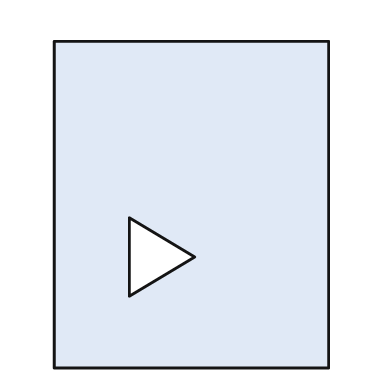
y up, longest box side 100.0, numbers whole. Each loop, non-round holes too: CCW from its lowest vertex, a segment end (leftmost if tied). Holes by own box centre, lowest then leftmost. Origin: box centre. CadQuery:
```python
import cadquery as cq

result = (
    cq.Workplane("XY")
    .moveTo(-42.0, -50.0)
    .lineTo(42.0, -50.0)
    .lineTo(42.0, 50.0)
    .lineTo(-42.0, 50.0)
    .close()
    .moveTo(-19.0, -28.0)
    .lineTo(1.0, -16.0)
    .lineTo(-19.0, -4.0)
    .close()
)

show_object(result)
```